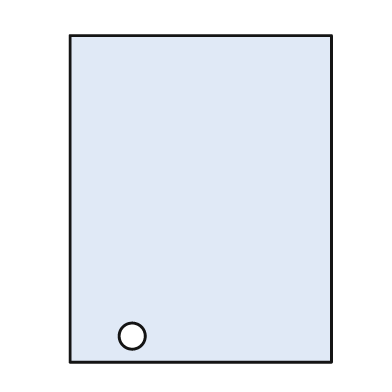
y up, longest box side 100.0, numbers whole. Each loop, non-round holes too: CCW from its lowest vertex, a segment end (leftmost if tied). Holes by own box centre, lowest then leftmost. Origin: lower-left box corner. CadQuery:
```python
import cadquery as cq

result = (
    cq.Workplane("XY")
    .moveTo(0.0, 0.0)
    .lineTo(80.0, 0.0)
    .lineTo(80.0, 100.0)
    .lineTo(0.0, 100.0)
    .close()
    .moveTo(19.0, 8.0)
    .circle(4.0)
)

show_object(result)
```